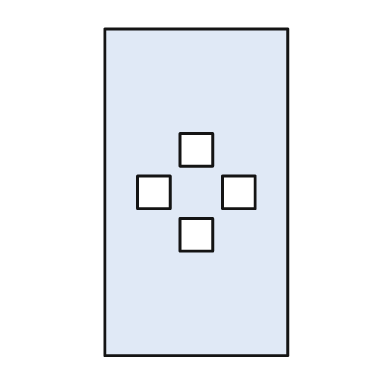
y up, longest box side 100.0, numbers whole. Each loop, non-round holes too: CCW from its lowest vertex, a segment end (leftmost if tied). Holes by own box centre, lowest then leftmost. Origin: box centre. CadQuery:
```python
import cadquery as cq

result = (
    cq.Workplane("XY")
    .moveTo(-28.0, -50.0)
    .lineTo(28.0, -50.0)
    .lineTo(28.0, 50.0)
    .lineTo(-28.0, 50.0)
    .close()
    .moveTo(-5.0, -18.0)
    .lineTo(5.0, -18.0)
    .lineTo(5.0, -8.0)
    .lineTo(-5.0, -8.0)
    .close()
    .moveTo(-18.0, -5.0)
    .lineTo(-8.0, -5.0)
    .lineTo(-8.0, 5.0)
    .lineTo(-18.0, 5.0)
    .close()
    .moveTo(8.0, -5.0)
    .lineTo(18.0, -5.0)
    .lineTo(18.0, 5.0)
    .lineTo(8.0, 5.0)
    .close()
    .moveTo(-5.0, 8.0)
    .lineTo(5.0, 8.0)
    .lineTo(5.0, 18.0)
    .lineTo(-5.0, 18.0)
    .close()
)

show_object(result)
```